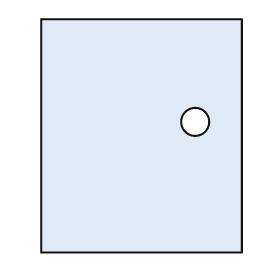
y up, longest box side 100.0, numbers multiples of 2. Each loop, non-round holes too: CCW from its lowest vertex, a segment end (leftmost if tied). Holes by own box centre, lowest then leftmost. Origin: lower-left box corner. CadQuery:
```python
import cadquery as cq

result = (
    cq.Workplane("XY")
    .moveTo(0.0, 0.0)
    .lineTo(86.0, 0.0)
    .lineTo(86.0, 100.0)
    .lineTo(0.0, 100.0)
    .close()
    .moveTo(66.0, 56.0)
    .circle(6.0)
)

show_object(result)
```